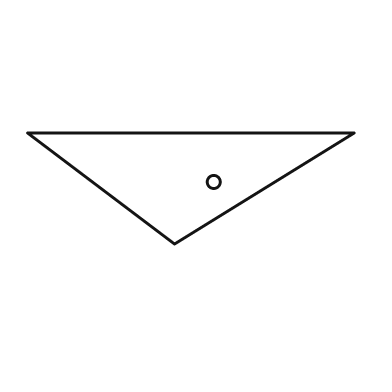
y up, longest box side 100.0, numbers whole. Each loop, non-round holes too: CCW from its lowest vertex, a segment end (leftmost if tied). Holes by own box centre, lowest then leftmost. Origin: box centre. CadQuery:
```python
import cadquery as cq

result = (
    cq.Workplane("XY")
    .moveTo(-5.0, -17.0)
    .lineTo(50.0, 17.0)
    .lineTo(-50.0, 17.0)
    .close()
    .moveTo(7.0, 2.0)
    .circle(2.0)
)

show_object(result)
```